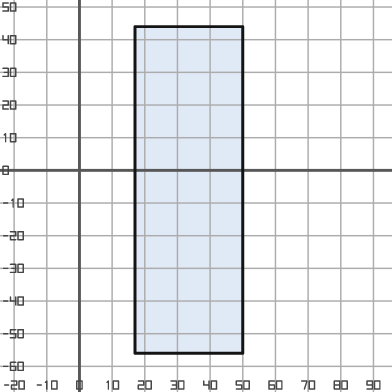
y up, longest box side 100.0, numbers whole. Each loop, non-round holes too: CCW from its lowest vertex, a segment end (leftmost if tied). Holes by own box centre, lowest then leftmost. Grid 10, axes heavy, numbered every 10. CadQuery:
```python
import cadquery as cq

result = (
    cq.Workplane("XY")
    .moveTo(17.0, -56.0)
    .lineTo(50.0, -56.0)
    .lineTo(50.0, 44.0)
    .lineTo(17.0, 44.0)
    .close()
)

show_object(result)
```